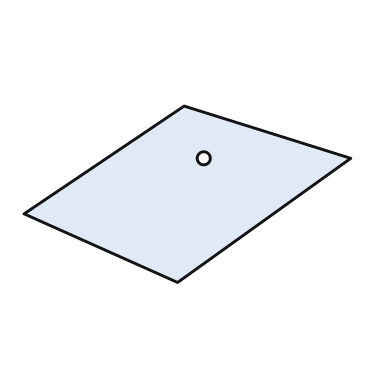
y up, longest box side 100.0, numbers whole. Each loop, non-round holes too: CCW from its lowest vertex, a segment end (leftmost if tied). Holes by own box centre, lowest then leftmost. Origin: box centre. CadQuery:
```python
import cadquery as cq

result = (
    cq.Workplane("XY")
    .moveTo(-3.0, -27.0)
    .lineTo(50.0, 11.0)
    .lineTo(-1.0, 27.0)
    .lineTo(-50.0, -6.0)
    .close()
    .moveTo(5.0, 11.0)
    .circle(2.0)
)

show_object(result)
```